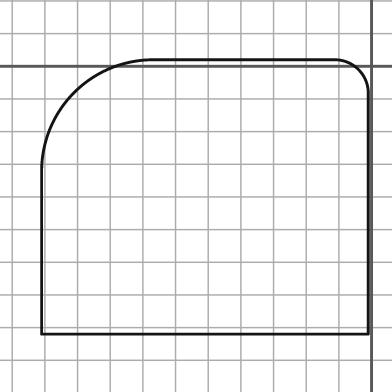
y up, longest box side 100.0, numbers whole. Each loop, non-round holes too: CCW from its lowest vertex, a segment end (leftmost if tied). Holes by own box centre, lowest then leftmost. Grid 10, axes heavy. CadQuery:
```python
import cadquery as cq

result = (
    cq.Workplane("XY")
    .moveTo(-101.0, -82.0)
    .lineTo(-1.0, -82.0)
    .lineTo(-1.0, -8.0)
    .threePointArc((-4.0, -1.0), (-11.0, 2.0))
    .lineTo(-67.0, 2.0)
    .threePointArc((-91.0, -8.0), (-101.0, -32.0))
    .close()
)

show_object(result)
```